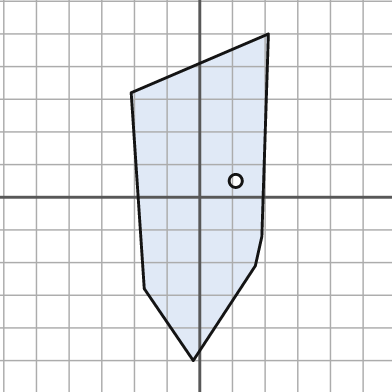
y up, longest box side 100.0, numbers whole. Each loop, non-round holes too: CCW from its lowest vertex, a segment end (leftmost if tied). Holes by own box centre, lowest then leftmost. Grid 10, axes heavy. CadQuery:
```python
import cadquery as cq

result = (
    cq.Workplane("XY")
    .moveTo(-2.0, -50.0)
    .lineTo(17.0, -21.0)
    .lineTo(19.0, -12.0)
    .lineTo(21.0, 50.0)
    .lineTo(-21.0, 32.0)
    .lineTo(-17.0, -28.0)
    .close()
    .moveTo(11.0, 5.0)
    .circle(2.0)
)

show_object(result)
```